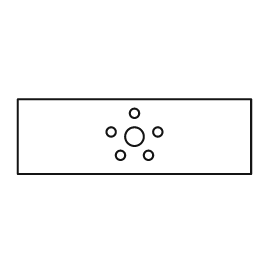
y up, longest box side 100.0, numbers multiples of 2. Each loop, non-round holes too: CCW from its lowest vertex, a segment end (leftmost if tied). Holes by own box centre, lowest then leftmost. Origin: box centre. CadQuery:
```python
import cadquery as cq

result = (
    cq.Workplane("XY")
    .moveTo(-50.0, -16.0)
    .lineTo(50.0, -16.0)
    .lineTo(50.0, 16.0)
    .lineTo(-50.0, 16.0)
    .close()
    .moveTo(-6.0, -8.0)
    .circle(2.0)
    .moveTo(6.0, -8.0)
    .circle(2.0)
    .moveTo(0.0, 0.0)
    .circle(4.0)
    .moveTo(-10.0, 2.0)
    .circle(2.0)
    .moveTo(10.0, 2.0)
    .circle(2.0)
    .moveTo(0.0, 10.0)
    .circle(2.0)
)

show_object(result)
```